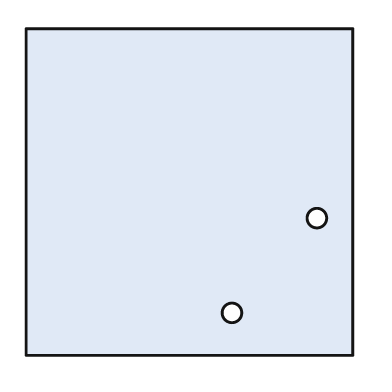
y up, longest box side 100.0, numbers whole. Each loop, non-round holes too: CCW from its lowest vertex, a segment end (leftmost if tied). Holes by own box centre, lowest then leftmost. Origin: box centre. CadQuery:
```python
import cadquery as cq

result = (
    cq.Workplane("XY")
    .moveTo(-50.0, -50.0)
    .lineTo(50.0, -50.0)
    .lineTo(50.0, 50.0)
    .lineTo(-50.0, 50.0)
    .close()
    .moveTo(13.0, -37.0)
    .circle(3.0)
    .moveTo(39.0, -8.0)
    .circle(3.0)
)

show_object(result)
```